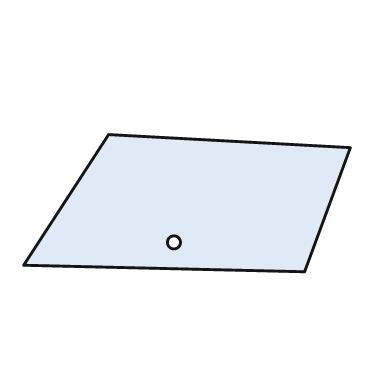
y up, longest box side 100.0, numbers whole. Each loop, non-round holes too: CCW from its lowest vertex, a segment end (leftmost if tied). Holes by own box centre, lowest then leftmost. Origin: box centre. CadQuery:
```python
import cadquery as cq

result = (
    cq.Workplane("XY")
    .moveTo(36.0, -21.0)
    .lineTo(50.0, 17.0)
    .lineTo(-24.0, 21.0)
    .lineTo(-50.0, -19.0)
    .close()
    .moveTo(-4.0, -12.0)
    .circle(2.0)
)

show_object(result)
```